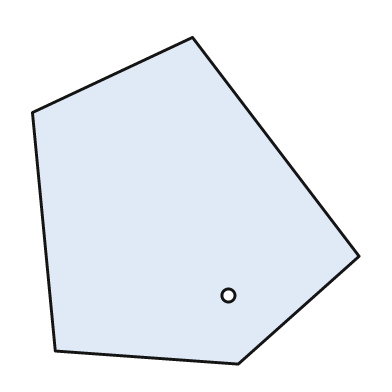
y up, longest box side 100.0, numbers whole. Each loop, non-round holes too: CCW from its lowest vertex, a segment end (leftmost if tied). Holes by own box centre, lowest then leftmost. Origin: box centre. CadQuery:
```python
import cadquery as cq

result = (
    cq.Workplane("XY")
    .moveTo(13.0, -50.0)
    .lineTo(50.0, -17.0)
    .lineTo(-1.0, 50.0)
    .lineTo(-50.0, 27.0)
    .lineTo(-43.0, -46.0)
    .close()
    .moveTo(10.0, -29.0)
    .circle(2.0)
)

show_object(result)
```